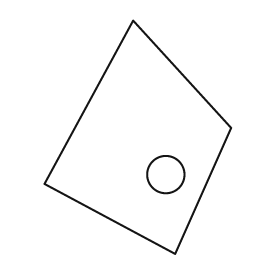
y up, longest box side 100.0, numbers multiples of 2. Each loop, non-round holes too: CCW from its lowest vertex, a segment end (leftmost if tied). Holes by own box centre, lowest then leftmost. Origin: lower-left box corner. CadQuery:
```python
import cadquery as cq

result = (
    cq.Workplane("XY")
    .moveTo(56.0, 0.0)
    .lineTo(80.0, 54.0)
    .lineTo(38.0, 100.0)
    .lineTo(0.0, 30.0)
    .close()
    .moveTo(52.0, 34.0)
    .circle(8.0)
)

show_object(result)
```